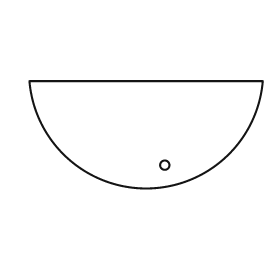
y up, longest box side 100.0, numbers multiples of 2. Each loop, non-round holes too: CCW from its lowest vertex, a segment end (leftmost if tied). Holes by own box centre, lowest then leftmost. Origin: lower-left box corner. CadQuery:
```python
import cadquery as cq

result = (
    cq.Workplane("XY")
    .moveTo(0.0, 46.0)
    .threePointArc((50.0, 0.0), (100.0, 46.0))
    .close()
    .moveTo(58.0, 10.0)
    .circle(2.0)
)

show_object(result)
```